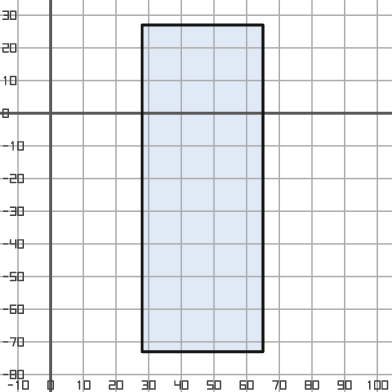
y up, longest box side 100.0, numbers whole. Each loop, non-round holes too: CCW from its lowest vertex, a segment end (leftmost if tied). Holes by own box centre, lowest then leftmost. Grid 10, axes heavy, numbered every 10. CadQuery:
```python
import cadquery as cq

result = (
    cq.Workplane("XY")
    .moveTo(28.0, -73.0)
    .lineTo(65.0, -73.0)
    .lineTo(65.0, 27.0)
    .lineTo(28.0, 27.0)
    .close()
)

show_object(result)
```